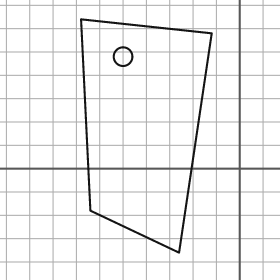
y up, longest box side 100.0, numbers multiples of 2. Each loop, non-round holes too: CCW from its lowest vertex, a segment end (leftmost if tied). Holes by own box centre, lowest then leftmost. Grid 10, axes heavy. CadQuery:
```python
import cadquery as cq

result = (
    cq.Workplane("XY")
    .moveTo(-26.0, -36.0)
    .lineTo(-12.0, 58.0)
    .lineTo(-68.0, 64.0)
    .lineTo(-64.0, -18.0)
    .close()
    .moveTo(-50.0, 48.0)
    .circle(4.0)
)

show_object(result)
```